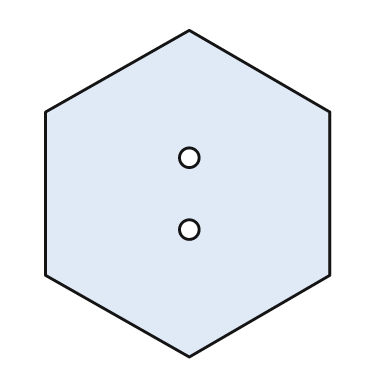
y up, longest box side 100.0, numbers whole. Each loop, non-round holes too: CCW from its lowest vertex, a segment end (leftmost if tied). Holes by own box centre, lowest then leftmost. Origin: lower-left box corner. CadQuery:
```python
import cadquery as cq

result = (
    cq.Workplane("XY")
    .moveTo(44.0, 0.0)
    .lineTo(87.0, 25.0)
    .lineTo(87.0, 75.0)
    .lineTo(44.0, 100.0)
    .lineTo(0.0, 75.0)
    .lineTo(0.0, 25.0)
    .close()
    .moveTo(44.0, 39.0)
    .circle(3.0)
    .moveTo(44.0, 61.0)
    .circle(3.0)
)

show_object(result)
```